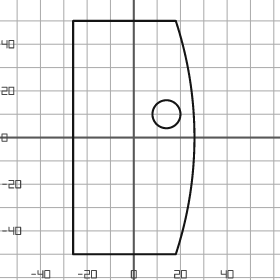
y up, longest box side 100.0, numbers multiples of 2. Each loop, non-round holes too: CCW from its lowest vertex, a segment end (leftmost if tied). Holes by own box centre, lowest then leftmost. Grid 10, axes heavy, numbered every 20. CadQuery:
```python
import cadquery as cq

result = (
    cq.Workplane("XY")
    .moveTo(-26.0, -50.0)
    .lineTo(18.0, -50.0)
    .threePointArc((26.0, 0.0), (18.0, 50.0))
    .lineTo(-26.0, 50.0)
    .close()
    .moveTo(14.0, 10.0)
    .circle(6.0)
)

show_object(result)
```